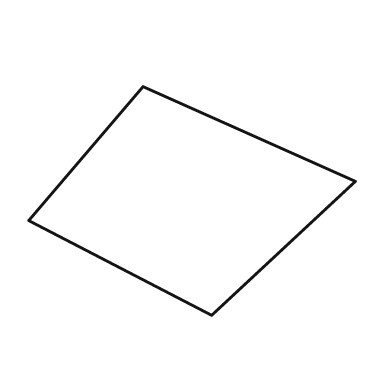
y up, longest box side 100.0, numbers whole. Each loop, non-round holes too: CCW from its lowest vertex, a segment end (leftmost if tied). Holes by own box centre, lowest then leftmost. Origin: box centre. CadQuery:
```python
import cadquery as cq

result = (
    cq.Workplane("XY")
    .moveTo(6.0, -35.0)
    .lineTo(50.0, 6.0)
    .lineTo(-15.0, 35.0)
    .lineTo(-50.0, -6.0)
    .close()
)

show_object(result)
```